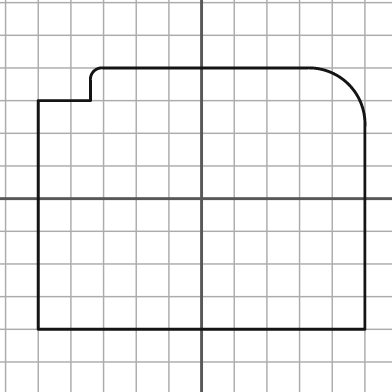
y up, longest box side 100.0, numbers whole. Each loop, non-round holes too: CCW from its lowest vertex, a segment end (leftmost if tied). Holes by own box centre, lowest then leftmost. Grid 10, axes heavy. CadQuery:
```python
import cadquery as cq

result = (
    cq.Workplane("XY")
    .moveTo(-50.0, -40.0)
    .lineTo(50.0, -40.0)
    .lineTo(50.0, 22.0)
    .threePointArc((45.0, 35.0), (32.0, 40.0))
    .lineTo(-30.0, 40.0)
    .threePointArc((-33.0, 39.0), (-34.0, 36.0))
    .lineTo(-34.0, 30.0)
    .lineTo(-50.0, 30.0)
    .close()
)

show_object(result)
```